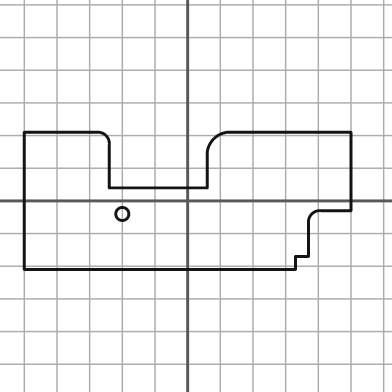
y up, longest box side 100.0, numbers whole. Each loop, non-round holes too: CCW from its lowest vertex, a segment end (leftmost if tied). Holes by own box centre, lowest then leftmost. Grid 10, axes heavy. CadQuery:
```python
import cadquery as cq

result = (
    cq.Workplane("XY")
    .moveTo(-50.0, -21.0)
    .lineTo(33.0, -21.0)
    .lineTo(33.0, -17.0)
    .lineTo(37.0, -17.0)
    .lineTo(37.0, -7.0)
    .threePointArc((38.0, -4.0), (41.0, -3.0))
    .lineTo(50.0, -3.0)
    .lineTo(50.0, 21.0)
    .lineTo(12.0, 21.0)
    .threePointArc((8.0, 19.0), (6.0, 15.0))
    .lineTo(6.0, 4.0)
    .lineTo(-24.0, 4.0)
    .lineTo(-24.0, 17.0)
    .threePointArc((-25.0, 20.0), (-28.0, 21.0))
    .lineTo(-50.0, 21.0)
    .close()
    .moveTo(-20.0, -4.0)
    .circle(2.0)
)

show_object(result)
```